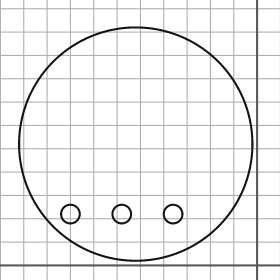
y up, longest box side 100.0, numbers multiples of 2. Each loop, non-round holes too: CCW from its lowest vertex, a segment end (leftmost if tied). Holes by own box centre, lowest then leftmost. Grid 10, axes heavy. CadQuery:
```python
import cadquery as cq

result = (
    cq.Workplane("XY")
    .moveTo(-52.0, 52.0)
    .circle(50.0)
    .moveTo(-80.0, 22.0)
    .circle(4.0)
    .moveTo(-58.0, 22.0)
    .circle(4.0)
    .moveTo(-36.0, 22.0)
    .circle(4.0)
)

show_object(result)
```